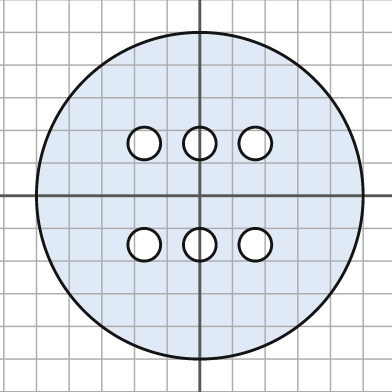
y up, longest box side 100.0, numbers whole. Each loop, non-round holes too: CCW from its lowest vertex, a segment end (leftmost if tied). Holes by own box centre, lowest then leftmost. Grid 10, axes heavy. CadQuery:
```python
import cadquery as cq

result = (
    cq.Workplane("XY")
    .moveTo(0.0, 0.0)
    .circle(50.0)
    .moveTo(-17.0, -15.0)
    .circle(5.0)
    .moveTo(0.0, -15.0)
    .circle(5.0)
    .moveTo(17.0, -15.0)
    .circle(5.0)
    .moveTo(-17.0, 16.0)
    .circle(5.0)
    .moveTo(0.0, 16.0)
    .circle(5.0)
    .moveTo(17.0, 16.0)
    .circle(5.0)
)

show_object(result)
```